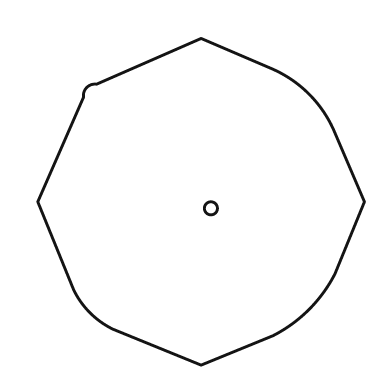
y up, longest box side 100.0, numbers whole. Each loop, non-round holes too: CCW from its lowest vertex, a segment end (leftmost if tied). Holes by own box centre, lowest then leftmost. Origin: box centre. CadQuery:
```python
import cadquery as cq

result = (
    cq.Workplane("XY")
    .moveTo(0.0, -50.0)
    .lineTo(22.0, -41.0)
    .threePointArc((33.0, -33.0), (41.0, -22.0))
    .lineTo(50.0, 0.0)
    .lineTo(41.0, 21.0)
    .threePointArc((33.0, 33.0), (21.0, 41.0))
    .lineTo(0.0, 50.0)
    .lineTo(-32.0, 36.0)
    .threePointArc((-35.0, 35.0), (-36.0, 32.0))
    .lineTo(-50.0, 0.0)
    .lineTo(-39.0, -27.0)
    .threePointArc((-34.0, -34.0), (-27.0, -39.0))
    .close()
    .moveTo(3.0, -2.0)
    .circle(2.0)
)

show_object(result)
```